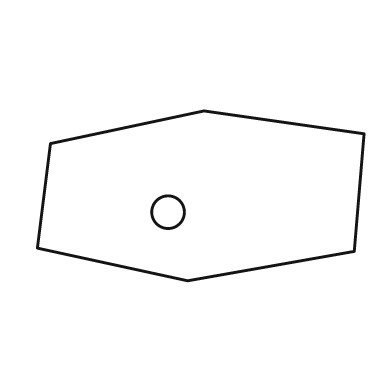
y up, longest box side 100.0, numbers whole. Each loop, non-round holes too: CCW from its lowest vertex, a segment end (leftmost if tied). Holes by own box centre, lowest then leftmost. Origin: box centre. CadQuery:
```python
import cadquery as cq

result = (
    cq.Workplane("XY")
    .moveTo(-4.0, -26.0)
    .lineTo(47.0, -17.0)
    .lineTo(50.0, 19.0)
    .lineTo(1.0, 26.0)
    .lineTo(-46.0, 16.0)
    .lineTo(-50.0, -16.0)
    .close()
    .moveTo(-10.0, -5.0)
    .circle(5.0)
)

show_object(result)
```